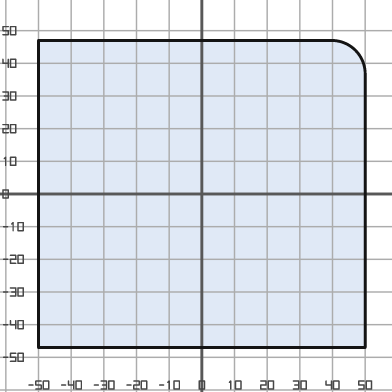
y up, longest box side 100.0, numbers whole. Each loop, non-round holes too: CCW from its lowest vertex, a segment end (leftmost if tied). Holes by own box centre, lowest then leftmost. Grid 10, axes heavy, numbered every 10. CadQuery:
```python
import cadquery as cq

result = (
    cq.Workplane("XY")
    .moveTo(-50.0, -47.0)
    .lineTo(50.0, -47.0)
    .lineTo(50.0, 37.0)
    .threePointArc((47.0, 44.0), (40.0, 47.0))
    .lineTo(-50.0, 47.0)
    .close()
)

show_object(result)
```